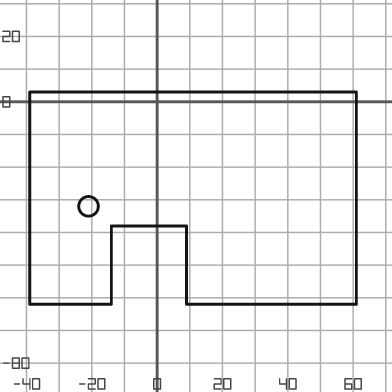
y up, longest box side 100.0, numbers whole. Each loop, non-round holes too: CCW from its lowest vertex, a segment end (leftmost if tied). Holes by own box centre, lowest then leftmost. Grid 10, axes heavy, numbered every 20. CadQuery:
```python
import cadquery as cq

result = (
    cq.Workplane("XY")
    .moveTo(-39.0, -62.0)
    .lineTo(-14.0, -62.0)
    .lineTo(-14.0, -38.0)
    .lineTo(9.0, -38.0)
    .lineTo(9.0, -62.0)
    .lineTo(61.0, -62.0)
    .lineTo(61.0, 3.0)
    .lineTo(-39.0, 3.0)
    .close()
    .moveTo(-21.0, -32.0)
    .circle(3.0)
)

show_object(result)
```